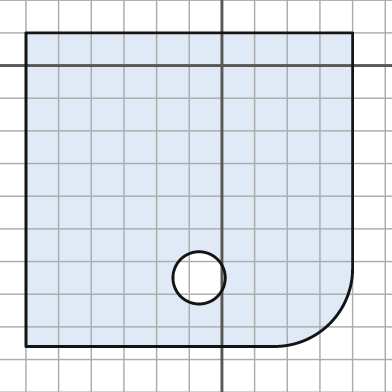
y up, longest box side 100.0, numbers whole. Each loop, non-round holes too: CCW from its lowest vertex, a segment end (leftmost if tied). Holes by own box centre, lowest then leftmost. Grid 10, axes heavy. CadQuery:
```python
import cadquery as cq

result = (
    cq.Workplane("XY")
    .moveTo(-60.0, -86.0)
    .lineTo(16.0, -86.0)
    .threePointArc((33.0, -79.0), (40.0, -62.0))
    .lineTo(40.0, 10.0)
    .lineTo(-60.0, 10.0)
    .close()
    .moveTo(-7.0, -65.0)
    .circle(8.0)
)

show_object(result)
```